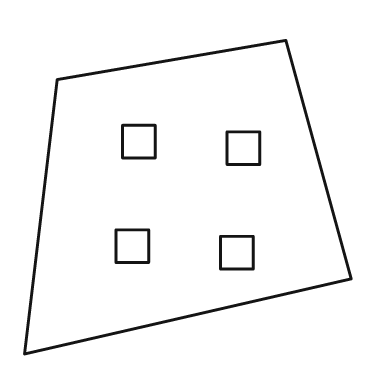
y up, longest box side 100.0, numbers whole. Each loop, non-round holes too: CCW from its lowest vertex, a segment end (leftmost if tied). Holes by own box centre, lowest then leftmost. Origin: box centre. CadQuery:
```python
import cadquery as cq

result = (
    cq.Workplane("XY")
    .moveTo(-50.0, -48.0)
    .lineTo(50.0, -25.0)
    .lineTo(30.0, 48.0)
    .lineTo(-40.0, 36.0)
    .close()
    .moveTo(10.0, -22.0)
    .lineTo(20.0, -22.0)
    .lineTo(20.0, -12.0)
    .lineTo(10.0, -12.0)
    .close()
    .moveTo(-22.0, -20.0)
    .lineTo(-12.0, -20.0)
    .lineTo(-12.0, -10.0)
    .lineTo(-22.0, -10.0)
    .close()
    .moveTo(12.0, 10.0)
    .lineTo(22.0, 10.0)
    .lineTo(22.0, 20.0)
    .lineTo(12.0, 20.0)
    .close()
    .moveTo(-20.0, 12.0)
    .lineTo(-10.0, 12.0)
    .lineTo(-10.0, 22.0)
    .lineTo(-20.0, 22.0)
    .close()
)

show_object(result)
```